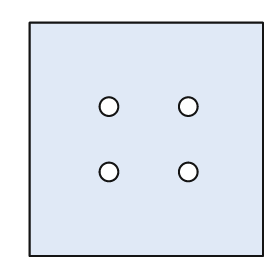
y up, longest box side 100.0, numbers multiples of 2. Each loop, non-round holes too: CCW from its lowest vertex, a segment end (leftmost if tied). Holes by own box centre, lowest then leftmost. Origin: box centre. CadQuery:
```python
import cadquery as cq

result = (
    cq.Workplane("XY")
    .moveTo(-50.0, -50.0)
    .lineTo(50.0, -50.0)
    .lineTo(50.0, 50.0)
    .lineTo(-50.0, 50.0)
    .close()
    .moveTo(-16.0, -14.0)
    .circle(4.0)
    .moveTo(18.0, -14.0)
    .circle(4.0)
    .moveTo(-16.0, 14.0)
    .circle(4.0)
    .moveTo(18.0, 14.0)
    .circle(4.0)
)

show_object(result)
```